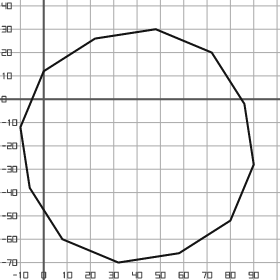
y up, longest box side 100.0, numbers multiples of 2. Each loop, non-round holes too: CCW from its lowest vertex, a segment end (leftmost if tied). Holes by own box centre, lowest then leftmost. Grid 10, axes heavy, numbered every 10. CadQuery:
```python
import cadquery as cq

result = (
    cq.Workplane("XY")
    .moveTo(32.0, -70.0)
    .lineTo(58.0, -66.0)
    .lineTo(80.0, -52.0)
    .lineTo(90.0, -28.0)
    .lineTo(86.0, -2.0)
    .lineTo(72.0, 20.0)
    .lineTo(48.0, 30.0)
    .lineTo(22.0, 26.0)
    .lineTo(0.0, 12.0)
    .lineTo(-10.0, -12.0)
    .lineTo(-6.0, -38.0)
    .lineTo(8.0, -60.0)
    .close()
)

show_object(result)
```